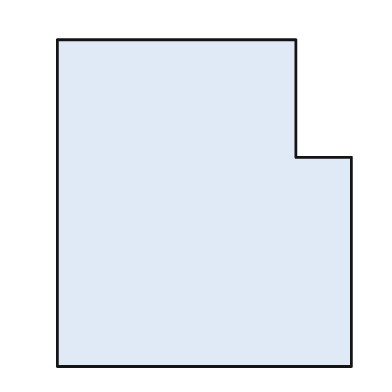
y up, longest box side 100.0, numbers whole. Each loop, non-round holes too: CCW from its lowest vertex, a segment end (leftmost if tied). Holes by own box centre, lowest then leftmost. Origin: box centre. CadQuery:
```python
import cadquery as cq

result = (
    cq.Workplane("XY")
    .moveTo(-45.0, -50.0)
    .lineTo(45.0, -50.0)
    .lineTo(45.0, 14.0)
    .lineTo(28.0, 14.0)
    .lineTo(28.0, 50.0)
    .lineTo(-45.0, 50.0)
    .close()
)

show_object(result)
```